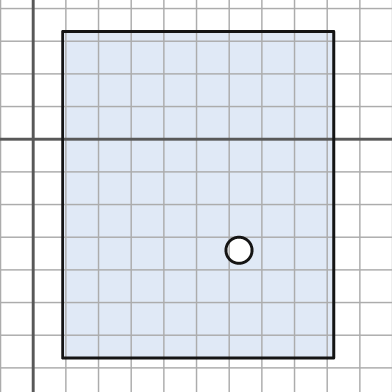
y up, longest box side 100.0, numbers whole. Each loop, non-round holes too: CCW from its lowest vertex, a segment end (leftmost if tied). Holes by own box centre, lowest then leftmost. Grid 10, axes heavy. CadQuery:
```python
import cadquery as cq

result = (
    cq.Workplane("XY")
    .moveTo(9.0, -67.0)
    .lineTo(92.0, -67.0)
    .lineTo(92.0, 33.0)
    .lineTo(9.0, 33.0)
    .close()
    .moveTo(63.0, -34.0)
    .circle(4.0)
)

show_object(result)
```